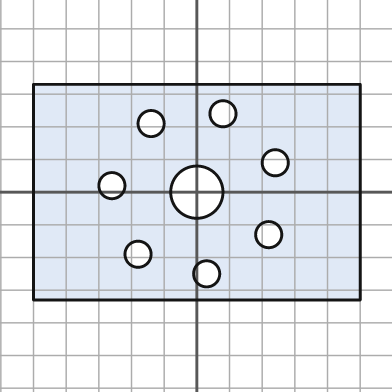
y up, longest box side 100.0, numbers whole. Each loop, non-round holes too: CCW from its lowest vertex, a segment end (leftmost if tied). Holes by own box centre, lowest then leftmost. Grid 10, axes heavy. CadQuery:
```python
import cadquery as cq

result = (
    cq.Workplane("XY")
    .moveTo(-50.0, -33.0)
    .lineTo(50.0, -33.0)
    .lineTo(50.0, 33.0)
    .lineTo(-50.0, 33.0)
    .close()
    .moveTo(3.0, -25.0)
    .circle(4.0)
    .moveTo(-18.0, -19.0)
    .circle(4.0)
    .moveTo(22.0, -13.0)
    .circle(4.0)
    .moveTo(0.0, 0.0)
    .circle(8.0)
    .moveTo(-26.0, 2.0)
    .circle(4.0)
    .moveTo(24.0, 9.0)
    .circle(4.0)
    .moveTo(-14.0, 21.0)
    .circle(4.0)
    .moveTo(8.0, 24.0)
    .circle(4.0)
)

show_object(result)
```